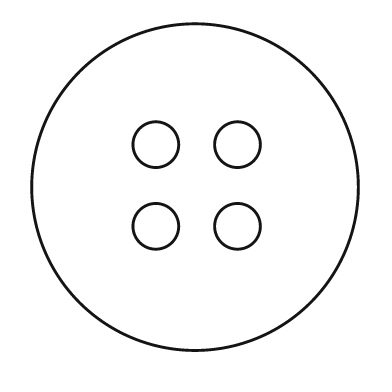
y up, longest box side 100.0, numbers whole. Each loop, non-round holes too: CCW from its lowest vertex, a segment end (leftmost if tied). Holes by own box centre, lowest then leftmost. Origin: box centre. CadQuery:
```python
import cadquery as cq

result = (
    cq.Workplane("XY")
    .moveTo(0.0, 0.0)
    .circle(50.0)
    .moveTo(-12.0, -12.0)
    .circle(7.0)
    .moveTo(13.0, -12.0)
    .circle(7.0)
    .moveTo(-12.0, 13.0)
    .circle(7.0)
    .moveTo(13.0, 13.0)
    .circle(7.0)
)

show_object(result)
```